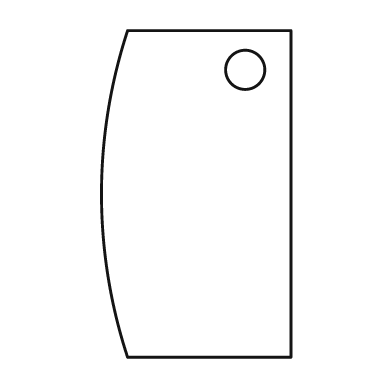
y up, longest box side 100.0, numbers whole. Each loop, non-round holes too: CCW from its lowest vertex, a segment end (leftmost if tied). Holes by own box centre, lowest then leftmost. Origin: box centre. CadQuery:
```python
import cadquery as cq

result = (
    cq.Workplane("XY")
    .moveTo(-21.0, -50.0)
    .lineTo(29.0, -50.0)
    .lineTo(29.0, 50.0)
    .lineTo(-21.0, 50.0)
    .threePointArc((-29.0, 0.0), (-21.0, -50.0))
    .close()
    .moveTo(15.0, 38.0)
    .circle(6.0)
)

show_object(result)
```